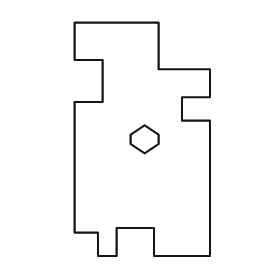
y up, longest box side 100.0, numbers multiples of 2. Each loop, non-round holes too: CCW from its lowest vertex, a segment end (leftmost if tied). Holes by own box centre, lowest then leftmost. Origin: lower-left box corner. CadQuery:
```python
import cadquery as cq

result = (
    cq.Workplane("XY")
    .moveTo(10.0, 0.0)
    .lineTo(18.0, 0.0)
    .lineTo(18.0, 12.0)
    .lineTo(34.0, 12.0)
    .lineTo(34.0, 0.0)
    .lineTo(58.0, 0.0)
    .lineTo(58.0, 58.0)
    .lineTo(46.0, 58.0)
    .lineTo(46.0, 68.0)
    .lineTo(58.0, 68.0)
    .lineTo(58.0, 80.0)
    .lineTo(36.0, 80.0)
    .lineTo(36.0, 100.0)
    .lineTo(0.0, 100.0)
    .lineTo(0.0, 84.0)
    .lineTo(12.0, 84.0)
    .lineTo(12.0, 66.0)
    .lineTo(0.0, 66.0)
    .lineTo(0.0, 10.0)
    .lineTo(10.0, 10.0)
    .close()
    .moveTo(30.0, 44.0)
    .lineTo(36.0, 48.0)
    .lineTo(36.0, 52.0)
    .lineTo(30.0, 56.0)
    .lineTo(24.0, 52.0)
    .lineTo(24.0, 48.0)
    .close()
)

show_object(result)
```